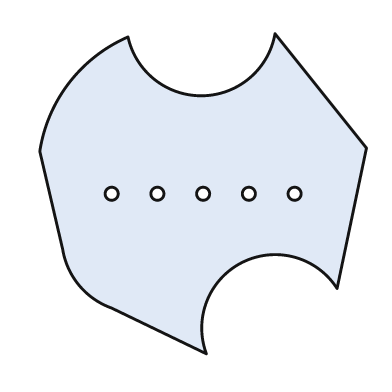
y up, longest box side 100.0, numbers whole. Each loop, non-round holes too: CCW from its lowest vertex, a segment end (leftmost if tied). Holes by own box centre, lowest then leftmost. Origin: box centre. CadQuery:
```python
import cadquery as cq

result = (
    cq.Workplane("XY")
    .moveTo(1.0, -49.0)
    .threePointArc((12.0, -21.0), (41.0, -29.0))
    .lineTo(50.0, 14.0)
    .lineTo(22.0, 49.0)
    .threePointArc((0.0, 30.0), (-23.0, 48.0))
    .threePointArc((-41.0, 34.0), (-50.0, 13.0))
    .lineTo(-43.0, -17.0)
    .threePointArc((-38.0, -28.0), (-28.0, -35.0))
    .close()
    .moveTo(-28.0, 0.0)
    .circle(2.0)
    .moveTo(-14.0, 0.0)
    .circle(2.0)
    .moveTo(0.0, 0.0)
    .circle(2.0)
    .moveTo(14.0, 0.0)
    .circle(2.0)
    .moveTo(28.0, 0.0)
    .circle(2.0)
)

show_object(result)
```